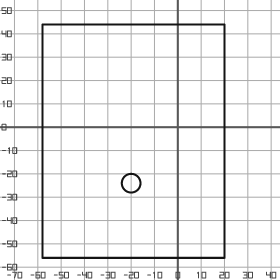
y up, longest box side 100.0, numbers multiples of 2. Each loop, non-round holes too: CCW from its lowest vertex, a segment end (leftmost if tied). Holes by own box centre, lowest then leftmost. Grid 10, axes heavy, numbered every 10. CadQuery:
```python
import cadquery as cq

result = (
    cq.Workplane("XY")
    .moveTo(-58.0, -56.0)
    .lineTo(20.0, -56.0)
    .lineTo(20.0, 44.0)
    .lineTo(-58.0, 44.0)
    .close()
    .moveTo(-20.0, -24.0)
    .circle(4.0)
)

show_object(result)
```